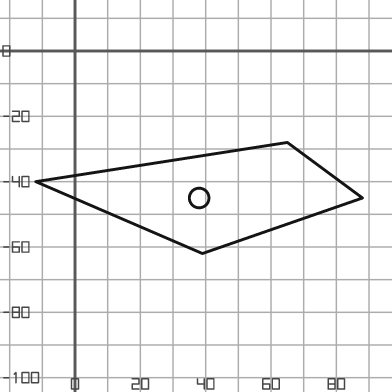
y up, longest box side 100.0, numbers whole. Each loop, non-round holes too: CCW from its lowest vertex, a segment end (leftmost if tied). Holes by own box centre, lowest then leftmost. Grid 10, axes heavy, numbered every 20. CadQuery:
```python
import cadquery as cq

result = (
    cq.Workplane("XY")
    .moveTo(39.0, -62.0)
    .lineTo(88.0, -45.0)
    .lineTo(65.0, -28.0)
    .lineTo(-12.0, -40.0)
    .close()
    .moveTo(38.0, -45.0)
    .circle(3.0)
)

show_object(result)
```